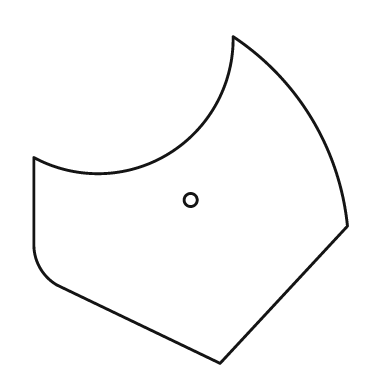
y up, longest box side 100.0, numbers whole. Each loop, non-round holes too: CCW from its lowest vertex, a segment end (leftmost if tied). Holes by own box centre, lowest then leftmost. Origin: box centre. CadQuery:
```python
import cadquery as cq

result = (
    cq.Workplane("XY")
    .moveTo(9.0, -50.0)
    .lineTo(48.0, -8.0)
    .threePointArc((37.0, 25.0), (13.0, 50.0))
    .threePointArc((-7.0, 14.0), (-48.0, 13.0))
    .lineTo(-48.0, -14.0)
    .threePointArc((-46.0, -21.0), (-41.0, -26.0))
    .close()
    .moveTo(0.0, 0.0)
    .circle(2.0)
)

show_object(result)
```